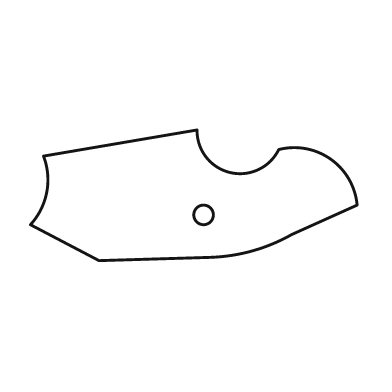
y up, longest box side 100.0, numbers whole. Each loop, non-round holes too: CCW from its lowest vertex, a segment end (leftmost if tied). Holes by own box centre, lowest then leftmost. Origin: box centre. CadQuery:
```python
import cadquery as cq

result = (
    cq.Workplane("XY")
    .moveTo(-29.0, -20.0)
    .lineTo(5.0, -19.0)
    .threePointArc((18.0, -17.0), (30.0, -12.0))
    .lineTo(50.0, -3.0)
    .threePointArc((42.0, 11.0), (26.0, 14.0))
    .threePointArc((11.0, 7.0), (1.0, 20.0))
    .lineTo(-46.0, 12.0)
    .threePointArc((-45.0, 1.0), (-50.0, -9.0))
    .close()
    .moveTo(3.0, -6.0)
    .circle(3.0)
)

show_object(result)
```